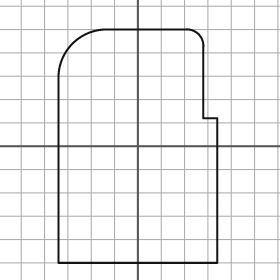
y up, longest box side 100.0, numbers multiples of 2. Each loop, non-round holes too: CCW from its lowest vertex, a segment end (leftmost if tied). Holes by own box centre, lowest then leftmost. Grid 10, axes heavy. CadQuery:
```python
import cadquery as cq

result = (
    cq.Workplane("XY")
    .moveTo(-34.0, -50.0)
    .lineTo(34.0, -50.0)
    .lineTo(34.0, 12.0)
    .lineTo(28.0, 12.0)
    .lineTo(28.0, 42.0)
    .threePointArc((26.0, 48.0), (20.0, 50.0))
    .lineTo(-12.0, 50.0)
    .threePointArc((-28.0, 44.0), (-34.0, 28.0))
    .close()
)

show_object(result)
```